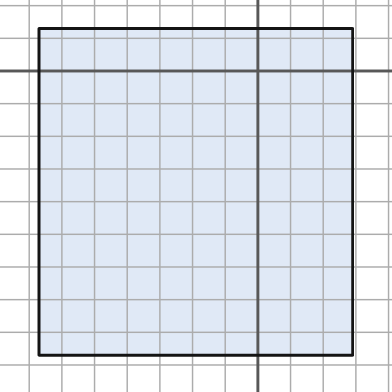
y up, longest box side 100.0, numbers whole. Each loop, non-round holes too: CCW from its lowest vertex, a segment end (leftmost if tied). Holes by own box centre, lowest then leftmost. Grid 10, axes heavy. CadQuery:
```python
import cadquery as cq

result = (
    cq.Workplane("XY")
    .moveTo(-67.0, -87.0)
    .lineTo(29.0, -87.0)
    .lineTo(29.0, 13.0)
    .lineTo(-67.0, 13.0)
    .close()
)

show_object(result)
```